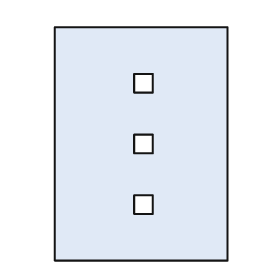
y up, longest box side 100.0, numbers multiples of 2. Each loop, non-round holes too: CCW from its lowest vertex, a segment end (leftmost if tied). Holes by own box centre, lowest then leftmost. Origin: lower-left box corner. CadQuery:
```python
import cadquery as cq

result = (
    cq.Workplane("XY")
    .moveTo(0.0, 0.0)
    .lineTo(74.0, 0.0)
    .lineTo(74.0, 100.0)
    .lineTo(0.0, 100.0)
    .close()
    .moveTo(34.0, 20.0)
    .lineTo(42.0, 20.0)
    .lineTo(42.0, 28.0)
    .lineTo(34.0, 28.0)
    .close()
    .moveTo(34.0, 46.0)
    .lineTo(42.0, 46.0)
    .lineTo(42.0, 54.0)
    .lineTo(34.0, 54.0)
    .close()
    .moveTo(34.0, 72.0)
    .lineTo(42.0, 72.0)
    .lineTo(42.0, 80.0)
    .lineTo(34.0, 80.0)
    .close()
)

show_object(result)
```